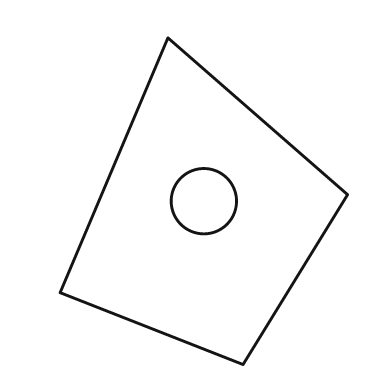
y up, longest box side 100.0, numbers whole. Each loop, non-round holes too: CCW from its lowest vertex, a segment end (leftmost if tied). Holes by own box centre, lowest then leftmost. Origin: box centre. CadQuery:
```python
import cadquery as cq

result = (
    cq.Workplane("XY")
    .moveTo(12.0, -50.0)
    .lineTo(44.0, 2.0)
    .lineTo(-11.0, 50.0)
    .lineTo(-44.0, -28.0)
    .close()
    .moveTo(0.0, 0.0)
    .circle(10.0)
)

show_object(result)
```